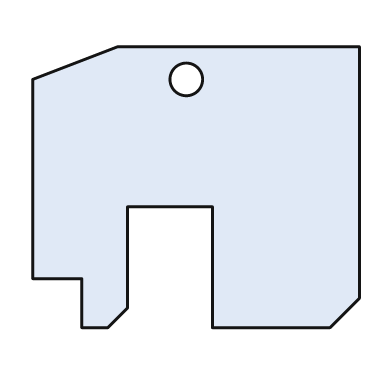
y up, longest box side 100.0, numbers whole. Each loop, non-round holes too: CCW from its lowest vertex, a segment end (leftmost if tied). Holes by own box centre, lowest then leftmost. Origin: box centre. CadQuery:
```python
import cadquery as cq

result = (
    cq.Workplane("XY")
    .moveTo(-35.0, -43.0)
    .lineTo(-27.0, -43.0)
    .lineTo(-21.0, -37.0)
    .lineTo(-21.0, -6.0)
    .lineTo(5.0, -6.0)
    .lineTo(5.0, -43.0)
    .lineTo(41.0, -43.0)
    .lineTo(50.0, -34.0)
    .lineTo(50.0, 43.0)
    .lineTo(-24.0, 43.0)
    .lineTo(-50.0, 33.0)
    .lineTo(-50.0, -28.0)
    .lineTo(-35.0, -28.0)
    .close()
    .moveTo(-3.0, 33.0)
    .circle(5.0)
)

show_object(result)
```